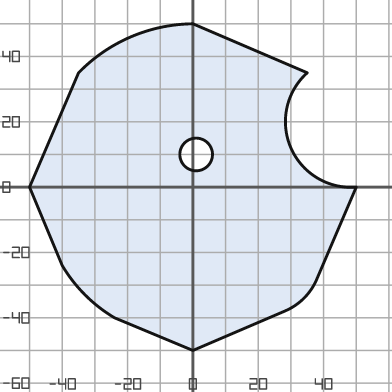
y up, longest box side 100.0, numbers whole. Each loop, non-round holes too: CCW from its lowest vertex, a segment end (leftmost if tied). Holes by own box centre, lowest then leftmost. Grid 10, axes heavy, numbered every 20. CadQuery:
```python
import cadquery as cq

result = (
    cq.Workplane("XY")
    .moveTo(0.0, -50.0)
    .lineTo(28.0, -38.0)
    .threePointArc((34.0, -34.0), (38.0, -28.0))
    .lineTo(50.0, 0.0)
    .threePointArc((30.0, 12.0), (35.0, 35.0))
    .lineTo(0.0, 50.0)
    .threePointArc((-19.0, 46.0), (-35.0, 35.0))
    .lineTo(-50.0, 0.0)
    .lineTo(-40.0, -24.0)
    .threePointArc((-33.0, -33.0), (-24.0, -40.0))
    .close()
    .moveTo(1.0, 10.0)
    .circle(5.0)
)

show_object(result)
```